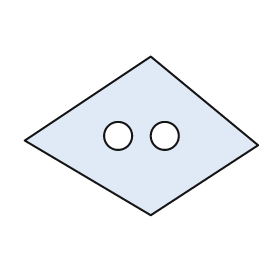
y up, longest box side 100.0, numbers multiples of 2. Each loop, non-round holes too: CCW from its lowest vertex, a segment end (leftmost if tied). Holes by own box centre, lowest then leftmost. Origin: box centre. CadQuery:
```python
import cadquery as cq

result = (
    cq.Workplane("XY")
    .moveTo(4.0, -34.0)
    .lineTo(50.0, -4.0)
    .lineTo(4.0, 34.0)
    .lineTo(-50.0, -2.0)
    .close()
    .moveTo(-10.0, 0.0)
    .circle(6.0)
    .moveTo(10.0, 0.0)
    .circle(6.0)
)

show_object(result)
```